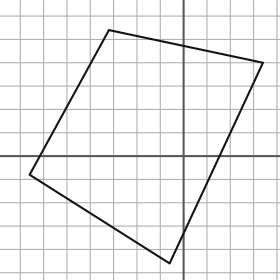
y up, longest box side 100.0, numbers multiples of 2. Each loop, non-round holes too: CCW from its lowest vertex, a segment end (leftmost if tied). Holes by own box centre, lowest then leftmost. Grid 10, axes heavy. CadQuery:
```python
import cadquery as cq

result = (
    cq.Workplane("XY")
    .moveTo(-6.0, -46.0)
    .lineTo(34.0, 40.0)
    .lineTo(-32.0, 54.0)
    .lineTo(-66.0, -8.0)
    .close()
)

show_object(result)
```